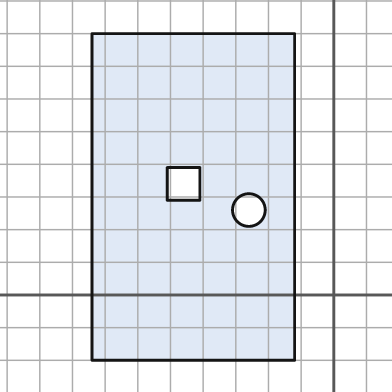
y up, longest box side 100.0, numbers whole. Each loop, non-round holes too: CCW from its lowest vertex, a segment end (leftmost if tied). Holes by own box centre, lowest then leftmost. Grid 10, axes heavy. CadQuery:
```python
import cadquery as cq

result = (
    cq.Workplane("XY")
    .moveTo(-74.0, -20.0)
    .lineTo(-12.0, -20.0)
    .lineTo(-12.0, 80.0)
    .lineTo(-74.0, 80.0)
    .close()
    .moveTo(-26.0, 26.0)
    .circle(5.0)
    .moveTo(-51.0, 29.0)
    .lineTo(-41.0, 29.0)
    .lineTo(-41.0, 39.0)
    .lineTo(-51.0, 39.0)
    .close()
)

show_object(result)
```